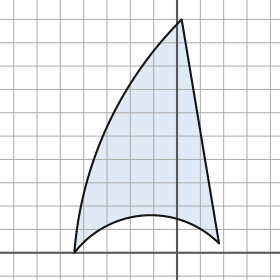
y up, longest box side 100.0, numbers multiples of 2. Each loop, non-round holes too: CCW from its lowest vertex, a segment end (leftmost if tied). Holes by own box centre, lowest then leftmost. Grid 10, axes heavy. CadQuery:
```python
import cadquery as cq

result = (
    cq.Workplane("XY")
    .moveTo(-44.0, 0.0)
    .threePointArc((-14.0, 16.0), (18.0, 4.0))
    .lineTo(2.0, 100.0)
    .threePointArc((-30.0, 54.0), (-44.0, 0.0))
    .close()
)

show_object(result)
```